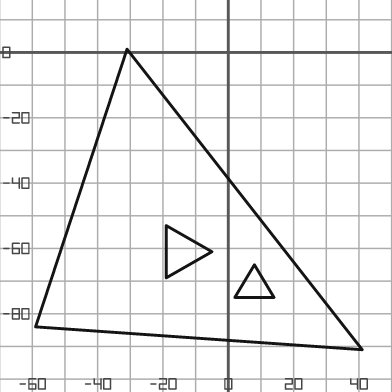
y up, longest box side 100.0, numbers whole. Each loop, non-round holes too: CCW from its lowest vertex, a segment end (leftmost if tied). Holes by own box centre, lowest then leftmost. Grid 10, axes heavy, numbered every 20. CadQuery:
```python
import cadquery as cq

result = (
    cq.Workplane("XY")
    .moveTo(41.0, -91.0)
    .lineTo(-31.0, 1.0)
    .lineTo(-59.0, -84.0)
    .close()
    .moveTo(2.0, -75.0)
    .lineTo(14.0, -75.0)
    .lineTo(8.0, -65.0)
    .close()
    .moveTo(-19.0, -69.0)
    .lineTo(-5.0, -61.0)
    .lineTo(-19.0, -53.0)
    .close()
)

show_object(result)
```